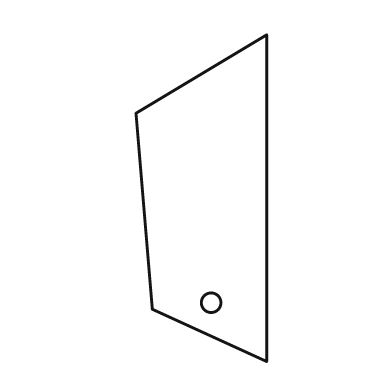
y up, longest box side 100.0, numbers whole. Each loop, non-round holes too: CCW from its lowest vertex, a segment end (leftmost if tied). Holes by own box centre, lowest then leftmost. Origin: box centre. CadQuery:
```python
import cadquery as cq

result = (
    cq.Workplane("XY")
    .moveTo(20.0, -50.0)
    .lineTo(20.0, 50.0)
    .lineTo(-20.0, 26.0)
    .lineTo(-15.0, -34.0)
    .close()
    .moveTo(3.0, -32.0)
    .circle(3.0)
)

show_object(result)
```